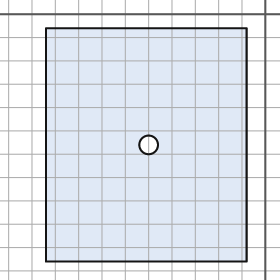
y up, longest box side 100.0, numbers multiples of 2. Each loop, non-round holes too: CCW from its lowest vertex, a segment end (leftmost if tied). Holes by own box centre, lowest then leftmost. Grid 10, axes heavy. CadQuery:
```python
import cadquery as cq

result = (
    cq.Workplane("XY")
    .moveTo(-94.0, -106.0)
    .lineTo(-8.0, -106.0)
    .lineTo(-8.0, -6.0)
    .lineTo(-94.0, -6.0)
    .close()
    .moveTo(-50.0, -56.0)
    .circle(4.0)
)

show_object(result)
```